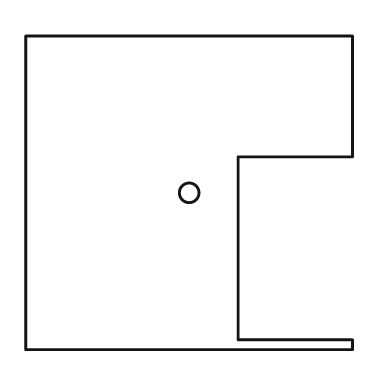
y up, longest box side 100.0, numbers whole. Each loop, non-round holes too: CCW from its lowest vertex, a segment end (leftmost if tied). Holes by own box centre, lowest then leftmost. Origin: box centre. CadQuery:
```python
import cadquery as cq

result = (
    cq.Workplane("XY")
    .moveTo(-50.0, -48.0)
    .lineTo(50.0, -48.0)
    .lineTo(50.0, -45.0)
    .lineTo(15.0, -45.0)
    .lineTo(15.0, 11.0)
    .lineTo(50.0, 11.0)
    .lineTo(50.0, 48.0)
    .lineTo(-50.0, 48.0)
    .close()
    .moveTo(0.0, 0.0)
    .circle(3.0)
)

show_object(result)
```